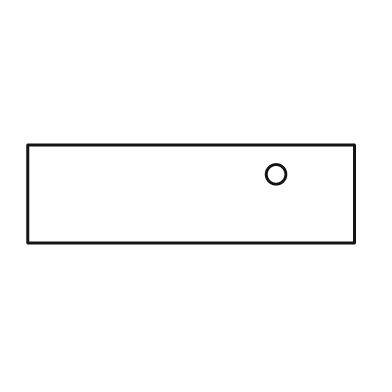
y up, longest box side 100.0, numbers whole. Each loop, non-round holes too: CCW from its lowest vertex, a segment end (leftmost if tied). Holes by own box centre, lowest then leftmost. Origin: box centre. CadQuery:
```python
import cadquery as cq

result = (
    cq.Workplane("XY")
    .moveTo(-50.0, -15.0)
    .lineTo(50.0, -15.0)
    .lineTo(50.0, 15.0)
    .lineTo(-50.0, 15.0)
    .close()
    .moveTo(26.0, 6.0)
    .circle(3.0)
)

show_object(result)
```